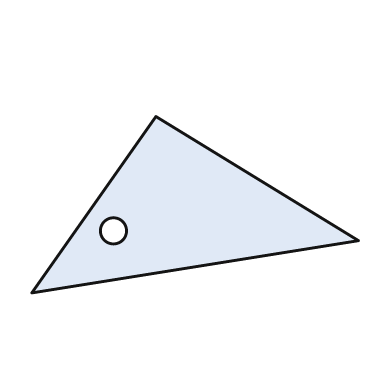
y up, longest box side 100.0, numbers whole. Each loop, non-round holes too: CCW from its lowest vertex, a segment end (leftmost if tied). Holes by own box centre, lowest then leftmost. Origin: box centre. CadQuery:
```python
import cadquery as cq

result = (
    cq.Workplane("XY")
    .moveTo(-50.0, -27.0)
    .lineTo(50.0, -11.0)
    .lineTo(-12.0, 27.0)
    .close()
    .moveTo(-25.0, -8.0)
    .circle(4.0)
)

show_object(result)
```